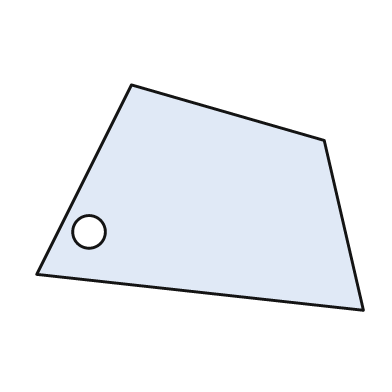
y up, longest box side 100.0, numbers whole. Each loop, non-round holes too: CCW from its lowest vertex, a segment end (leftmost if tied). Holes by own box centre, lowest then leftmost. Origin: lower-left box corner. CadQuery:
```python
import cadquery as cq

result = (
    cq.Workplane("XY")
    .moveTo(100.0, 0.0)
    .lineTo(88.0, 52.0)
    .lineTo(29.0, 69.0)
    .lineTo(0.0, 11.0)
    .close()
    .moveTo(16.0, 24.0)
    .circle(5.0)
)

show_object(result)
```